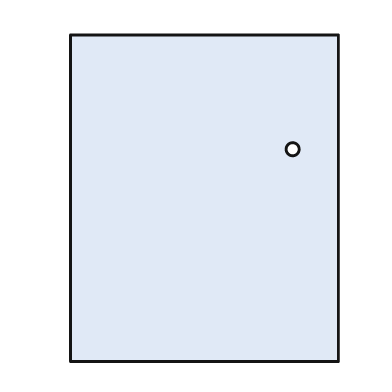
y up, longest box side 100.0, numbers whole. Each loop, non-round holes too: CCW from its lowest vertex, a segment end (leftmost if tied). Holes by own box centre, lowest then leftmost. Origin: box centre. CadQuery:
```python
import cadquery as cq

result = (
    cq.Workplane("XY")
    .moveTo(-41.0, -50.0)
    .lineTo(41.0, -50.0)
    .lineTo(41.0, 50.0)
    .lineTo(-41.0, 50.0)
    .close()
    .moveTo(27.0, 15.0)
    .circle(2.0)
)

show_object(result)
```